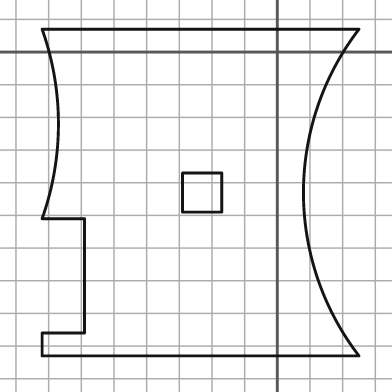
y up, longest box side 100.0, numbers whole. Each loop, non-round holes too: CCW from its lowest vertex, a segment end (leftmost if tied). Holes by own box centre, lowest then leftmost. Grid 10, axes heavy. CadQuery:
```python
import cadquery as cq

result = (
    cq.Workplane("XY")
    .moveTo(-72.0, -93.0)
    .lineTo(25.0, -93.0)
    .threePointArc((8.0, -43.0), (25.0, 7.0))
    .lineTo(-72.0, 7.0)
    .threePointArc((-67.0, -22.0), (-72.0, -51.0))
    .lineTo(-59.0, -51.0)
    .lineTo(-59.0, -86.0)
    .lineTo(-72.0, -86.0)
    .close()
    .moveTo(-29.0, -49.0)
    .lineTo(-17.0, -49.0)
    .lineTo(-17.0, -37.0)
    .lineTo(-29.0, -37.0)
    .close()
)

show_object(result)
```